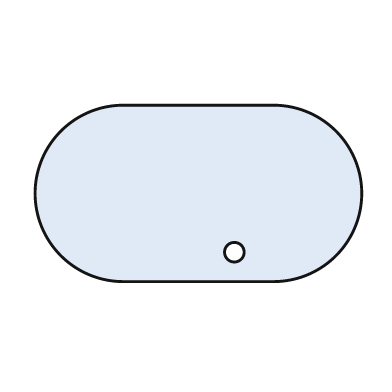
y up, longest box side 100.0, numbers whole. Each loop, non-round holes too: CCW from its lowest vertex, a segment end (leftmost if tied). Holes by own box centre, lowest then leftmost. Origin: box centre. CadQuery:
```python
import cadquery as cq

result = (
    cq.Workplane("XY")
    .moveTo(-23.0, -27.0)
    .lineTo(23.0, -27.0)
    .threePointArc((50.0, 0.0), (23.0, 27.0))
    .lineTo(-23.0, 27.0)
    .threePointArc((-50.0, 0.0), (-23.0, -27.0))
    .close()
    .moveTo(11.0, -18.0)
    .circle(3.0)
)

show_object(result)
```